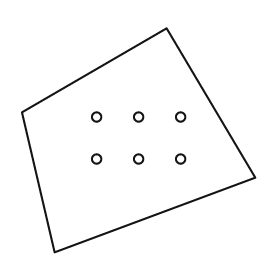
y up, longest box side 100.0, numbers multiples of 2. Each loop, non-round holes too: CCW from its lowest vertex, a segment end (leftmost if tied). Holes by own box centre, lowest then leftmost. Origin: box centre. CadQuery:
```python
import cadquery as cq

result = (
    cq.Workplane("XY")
    .moveTo(-36.0, -48.0)
    .lineTo(50.0, -16.0)
    .lineTo(12.0, 48.0)
    .lineTo(-50.0, 12.0)
    .close()
    .moveTo(-18.0, -8.0)
    .circle(2.0)
    .moveTo(0.0, -8.0)
    .circle(2.0)
    .moveTo(18.0, -8.0)
    .circle(2.0)
    .moveTo(-18.0, 10.0)
    .circle(2.0)
    .moveTo(0.0, 10.0)
    .circle(2.0)
    .moveTo(18.0, 10.0)
    .circle(2.0)
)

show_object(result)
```